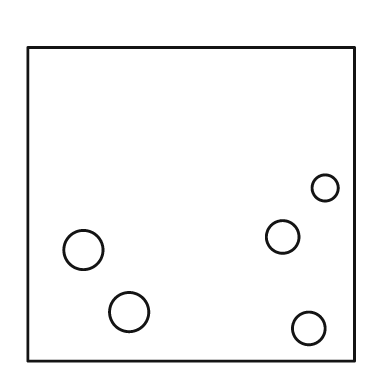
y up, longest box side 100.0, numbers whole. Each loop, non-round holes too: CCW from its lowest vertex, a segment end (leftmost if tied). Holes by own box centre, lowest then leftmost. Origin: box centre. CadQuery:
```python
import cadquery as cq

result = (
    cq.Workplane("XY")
    .moveTo(-50.0, -48.0)
    .lineTo(50.0, -48.0)
    .lineTo(50.0, 48.0)
    .lineTo(-50.0, 48.0)
    .close()
    .moveTo(36.0, -38.0)
    .circle(5.0)
    .moveTo(-19.0, -33.0)
    .circle(6.0)
    .moveTo(-33.0, -14.0)
    .circle(6.0)
    .moveTo(28.0, -10.0)
    .circle(5.0)
    .moveTo(41.0, 5.0)
    .circle(4.0)
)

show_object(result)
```